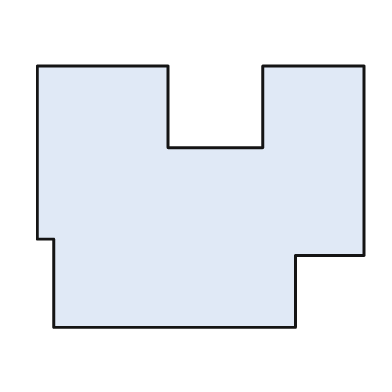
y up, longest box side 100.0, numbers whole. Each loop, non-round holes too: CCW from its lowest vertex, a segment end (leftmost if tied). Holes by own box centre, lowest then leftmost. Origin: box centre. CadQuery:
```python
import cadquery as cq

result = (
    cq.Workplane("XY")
    .moveTo(-45.0, -40.0)
    .lineTo(29.0, -40.0)
    .lineTo(29.0, -18.0)
    .lineTo(50.0, -18.0)
    .lineTo(50.0, 40.0)
    .lineTo(19.0, 40.0)
    .lineTo(19.0, 15.0)
    .lineTo(-10.0, 15.0)
    .lineTo(-10.0, 40.0)
    .lineTo(-50.0, 40.0)
    .lineTo(-50.0, -13.0)
    .lineTo(-45.0, -13.0)
    .close()
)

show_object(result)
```